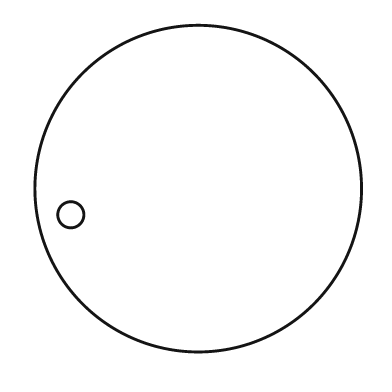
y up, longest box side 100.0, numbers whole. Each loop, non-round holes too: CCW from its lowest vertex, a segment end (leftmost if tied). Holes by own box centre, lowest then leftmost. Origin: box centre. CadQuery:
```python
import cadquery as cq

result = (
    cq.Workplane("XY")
    .moveTo(0.0, 0.0)
    .circle(50.0)
    .moveTo(-39.0, -8.0)
    .circle(4.0)
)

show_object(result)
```